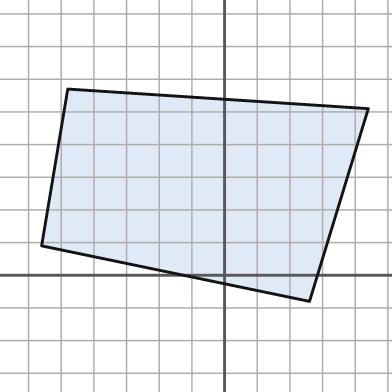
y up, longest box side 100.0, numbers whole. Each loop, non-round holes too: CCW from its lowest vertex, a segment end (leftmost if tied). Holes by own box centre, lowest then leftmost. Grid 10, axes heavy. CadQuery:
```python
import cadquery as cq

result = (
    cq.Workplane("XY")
    .moveTo(26.0, -8.0)
    .lineTo(44.0, 51.0)
    .lineTo(-48.0, 57.0)
    .lineTo(-56.0, 9.0)
    .close()
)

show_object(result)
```